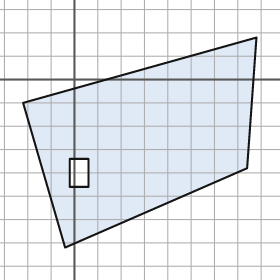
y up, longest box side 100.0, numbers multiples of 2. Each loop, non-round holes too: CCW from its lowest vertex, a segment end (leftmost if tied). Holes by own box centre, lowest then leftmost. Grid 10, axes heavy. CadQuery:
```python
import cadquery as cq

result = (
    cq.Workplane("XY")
    .moveTo(-4.0, -72.0)
    .lineTo(74.0, -38.0)
    .lineTo(78.0, 18.0)
    .lineTo(-22.0, -10.0)
    .close()
    .moveTo(-2.0, -46.0)
    .lineTo(6.0, -46.0)
    .lineTo(6.0, -34.0)
    .lineTo(-2.0, -34.0)
    .close()
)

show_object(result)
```